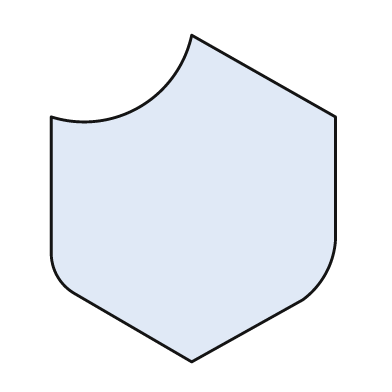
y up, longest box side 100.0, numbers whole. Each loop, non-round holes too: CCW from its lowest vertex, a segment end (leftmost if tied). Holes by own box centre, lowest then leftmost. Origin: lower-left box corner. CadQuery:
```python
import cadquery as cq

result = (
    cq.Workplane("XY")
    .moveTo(43.0, 0.0)
    .lineTo(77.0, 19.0)
    .threePointArc((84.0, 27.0), (87.0, 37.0))
    .lineTo(87.0, 75.0)
    .lineTo(43.0, 100.0)
    .threePointArc((27.0, 78.0), (0.0, 75.0))
    .lineTo(0.0, 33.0)
    .threePointArc((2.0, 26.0), (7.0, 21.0))
    .close()
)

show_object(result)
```